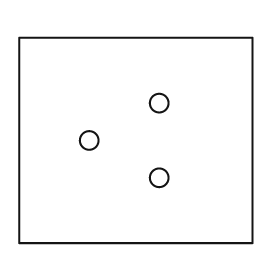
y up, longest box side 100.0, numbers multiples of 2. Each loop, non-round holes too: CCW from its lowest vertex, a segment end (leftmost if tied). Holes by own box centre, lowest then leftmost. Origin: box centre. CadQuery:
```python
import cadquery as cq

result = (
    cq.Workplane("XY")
    .moveTo(-50.0, -44.0)
    .lineTo(50.0, -44.0)
    .lineTo(50.0, 44.0)
    .lineTo(-50.0, 44.0)
    .close()
    .moveTo(10.0, -16.0)
    .circle(4.0)
    .moveTo(-20.0, 0.0)
    .circle(4.0)
    .moveTo(10.0, 16.0)
    .circle(4.0)
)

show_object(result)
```